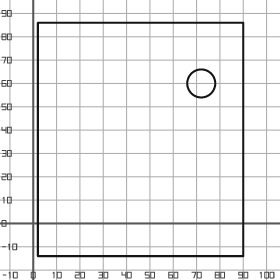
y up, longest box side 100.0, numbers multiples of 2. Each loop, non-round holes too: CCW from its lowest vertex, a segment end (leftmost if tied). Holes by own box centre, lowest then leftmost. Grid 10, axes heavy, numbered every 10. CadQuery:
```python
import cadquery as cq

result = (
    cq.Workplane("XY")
    .moveTo(2.0, -14.0)
    .lineTo(90.0, -14.0)
    .lineTo(90.0, 86.0)
    .lineTo(2.0, 86.0)
    .close()
    .moveTo(72.0, 60.0)
    .circle(6.0)
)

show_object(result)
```